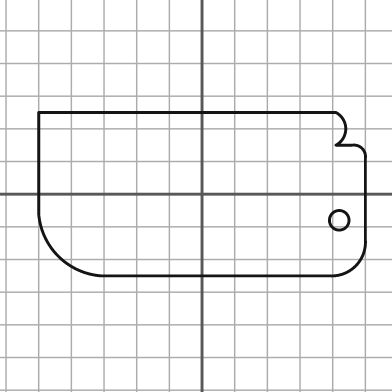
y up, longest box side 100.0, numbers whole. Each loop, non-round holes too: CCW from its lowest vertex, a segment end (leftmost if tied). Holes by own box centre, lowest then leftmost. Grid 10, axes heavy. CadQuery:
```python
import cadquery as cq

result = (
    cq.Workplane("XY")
    .moveTo(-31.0, -25.0)
    .lineTo(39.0, -25.0)
    .threePointArc((47.0, -22.0), (50.0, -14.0))
    .lineTo(50.0, 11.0)
    .threePointArc((49.0, 14.0), (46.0, 15.0))
    .lineTo(41.0, 15.0)
    .threePointArc((44.0, 20.0), (41.0, 25.0))
    .lineTo(-50.0, 25.0)
    .lineTo(-50.0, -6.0)
    .threePointArc((-44.0, -19.0), (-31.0, -25.0))
    .close()
    .moveTo(42.0, -8.0)
    .circle(3.0)
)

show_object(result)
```